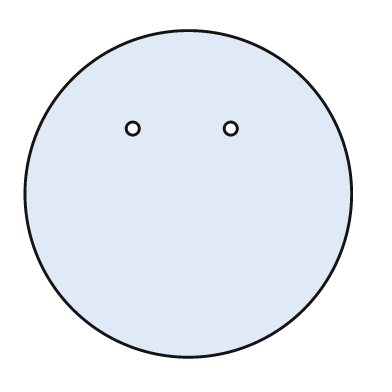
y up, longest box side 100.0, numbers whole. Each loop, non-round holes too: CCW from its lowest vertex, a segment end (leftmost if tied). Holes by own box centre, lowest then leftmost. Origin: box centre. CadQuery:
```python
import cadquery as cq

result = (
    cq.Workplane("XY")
    .moveTo(0.0, 0.0)
    .circle(50.0)
    .moveTo(-17.0, 20.0)
    .circle(2.0)
    .moveTo(13.0, 20.0)
    .circle(2.0)
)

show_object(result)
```